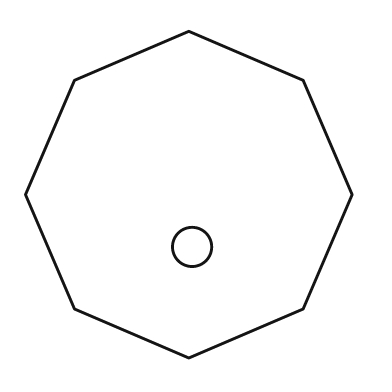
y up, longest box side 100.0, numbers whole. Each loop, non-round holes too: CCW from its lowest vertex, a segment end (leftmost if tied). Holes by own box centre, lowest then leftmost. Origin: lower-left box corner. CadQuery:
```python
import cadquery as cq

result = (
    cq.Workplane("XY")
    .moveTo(50.0, 0.0)
    .lineTo(85.0, 15.0)
    .lineTo(100.0, 50.0)
    .lineTo(85.0, 85.0)
    .lineTo(50.0, 100.0)
    .lineTo(15.0, 85.0)
    .lineTo(0.0, 50.0)
    .lineTo(15.0, 15.0)
    .close()
    .moveTo(51.0, 34.0)
    .circle(6.0)
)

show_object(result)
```